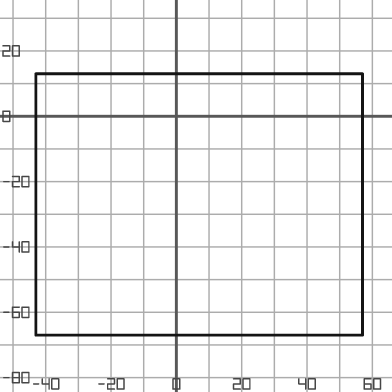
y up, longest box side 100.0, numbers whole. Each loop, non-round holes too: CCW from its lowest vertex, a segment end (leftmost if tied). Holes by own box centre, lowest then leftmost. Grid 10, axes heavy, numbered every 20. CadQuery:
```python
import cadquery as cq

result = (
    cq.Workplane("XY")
    .moveTo(-43.0, -67.0)
    .lineTo(57.0, -67.0)
    .lineTo(57.0, 13.0)
    .lineTo(-43.0, 13.0)
    .close()
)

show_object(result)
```